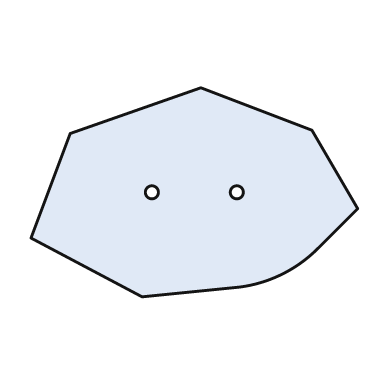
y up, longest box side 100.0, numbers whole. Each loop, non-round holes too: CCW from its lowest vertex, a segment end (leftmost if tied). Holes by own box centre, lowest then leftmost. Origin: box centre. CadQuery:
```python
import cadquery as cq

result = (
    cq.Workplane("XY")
    .moveTo(-16.0, -32.0)
    .lineTo(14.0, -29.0)
    .threePointArc((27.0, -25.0), (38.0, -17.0))
    .lineTo(50.0, -5.0)
    .lineTo(36.0, 19.0)
    .lineTo(2.0, 32.0)
    .lineTo(-38.0, 18.0)
    .lineTo(-50.0, -14.0)
    .close()
    .moveTo(-13.0, 0.0)
    .circle(2.0)
    .moveTo(13.0, 0.0)
    .circle(2.0)
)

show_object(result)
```